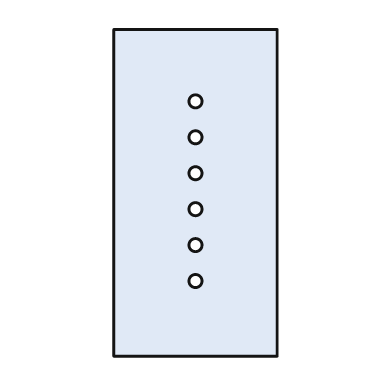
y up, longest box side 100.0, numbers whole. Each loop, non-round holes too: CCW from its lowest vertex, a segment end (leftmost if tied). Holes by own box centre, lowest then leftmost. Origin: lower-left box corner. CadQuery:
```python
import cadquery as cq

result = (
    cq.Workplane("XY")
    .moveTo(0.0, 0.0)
    .lineTo(50.0, 0.0)
    .lineTo(50.0, 100.0)
    .lineTo(0.0, 100.0)
    .close()
    .moveTo(25.0, 23.0)
    .circle(2.0)
    .moveTo(25.0, 34.0)
    .circle(2.0)
    .moveTo(25.0, 45.0)
    .circle(2.0)
    .moveTo(25.0, 56.0)
    .circle(2.0)
    .moveTo(25.0, 67.0)
    .circle(2.0)
    .moveTo(25.0, 78.0)
    .circle(2.0)
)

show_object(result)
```